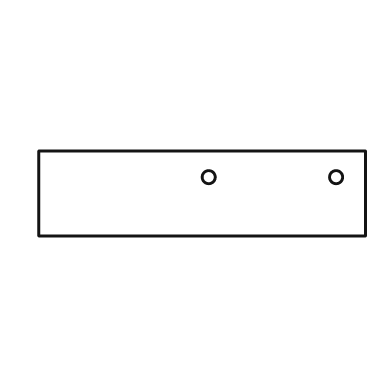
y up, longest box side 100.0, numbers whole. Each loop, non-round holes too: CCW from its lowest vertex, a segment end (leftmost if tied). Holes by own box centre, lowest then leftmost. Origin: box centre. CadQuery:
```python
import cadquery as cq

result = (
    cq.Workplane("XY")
    .moveTo(-50.0, -13.0)
    .lineTo(50.0, -13.0)
    .lineTo(50.0, 13.0)
    .lineTo(-50.0, 13.0)
    .close()
    .moveTo(2.0, 5.0)
    .circle(2.0)
    .moveTo(41.0, 5.0)
    .circle(2.0)
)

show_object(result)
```